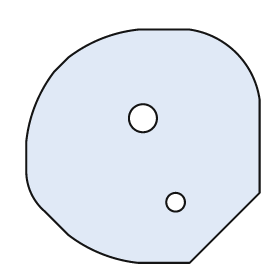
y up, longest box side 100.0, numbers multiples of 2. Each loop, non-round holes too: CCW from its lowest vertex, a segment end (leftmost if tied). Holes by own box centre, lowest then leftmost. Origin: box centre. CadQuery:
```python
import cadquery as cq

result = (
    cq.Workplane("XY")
    .moveTo(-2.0, -50.0)
    .lineTo(20.0, -50.0)
    .lineTo(50.0, -20.0)
    .lineTo(50.0, 20.0)
    .threePointArc((40.0, 40.0), (20.0, 50.0))
    .lineTo(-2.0, 50.0)
    .threePointArc((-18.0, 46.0), (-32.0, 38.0))
    .lineTo(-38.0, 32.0)
    .threePointArc((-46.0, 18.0), (-50.0, 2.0))
    .lineTo(-50.0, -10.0)
    .threePointArc((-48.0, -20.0), (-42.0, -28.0))
    .lineTo(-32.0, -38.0)
    .threePointArc((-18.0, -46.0), (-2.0, -50.0))
    .close()
    .moveTo(14.0, -24.0)
    .circle(4.0)
    .moveTo(0.0, 12.0)
    .circle(6.0)
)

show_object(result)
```